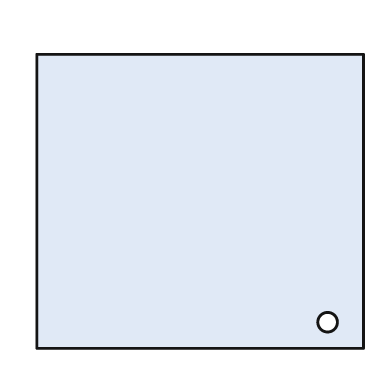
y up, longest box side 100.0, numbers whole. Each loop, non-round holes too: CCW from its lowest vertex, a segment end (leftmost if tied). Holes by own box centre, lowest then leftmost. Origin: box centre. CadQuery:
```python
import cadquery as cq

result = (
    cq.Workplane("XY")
    .moveTo(-50.0, -45.0)
    .lineTo(50.0, -45.0)
    .lineTo(50.0, 45.0)
    .lineTo(-50.0, 45.0)
    .close()
    .moveTo(39.0, -37.0)
    .circle(3.0)
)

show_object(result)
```